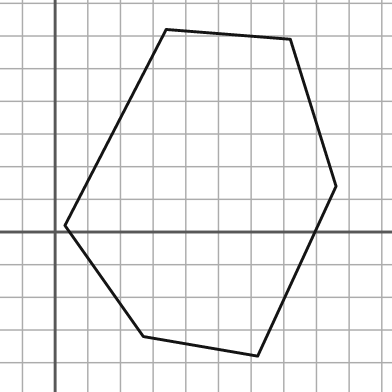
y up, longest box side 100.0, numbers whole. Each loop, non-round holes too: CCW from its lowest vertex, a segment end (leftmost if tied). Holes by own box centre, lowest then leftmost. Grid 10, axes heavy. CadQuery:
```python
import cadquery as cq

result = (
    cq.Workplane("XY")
    .moveTo(62.0, -38.0)
    .lineTo(86.0, 14.0)
    .lineTo(72.0, 59.0)
    .lineTo(34.0, 62.0)
    .lineTo(3.0, 2.0)
    .lineTo(27.0, -32.0)
    .close()
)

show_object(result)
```